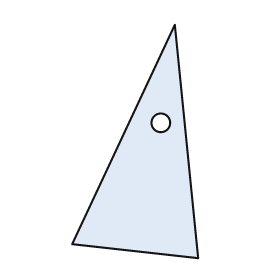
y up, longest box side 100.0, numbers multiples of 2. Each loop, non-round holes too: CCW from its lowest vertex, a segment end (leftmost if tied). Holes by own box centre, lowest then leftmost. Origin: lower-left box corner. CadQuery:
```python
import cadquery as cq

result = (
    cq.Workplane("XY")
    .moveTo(54.0, 0.0)
    .lineTo(44.0, 100.0)
    .lineTo(0.0, 6.0)
    .close()
    .moveTo(38.0, 58.0)
    .circle(4.0)
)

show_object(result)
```